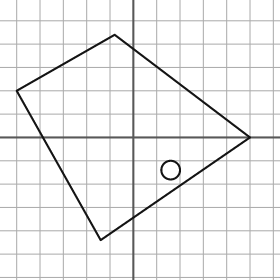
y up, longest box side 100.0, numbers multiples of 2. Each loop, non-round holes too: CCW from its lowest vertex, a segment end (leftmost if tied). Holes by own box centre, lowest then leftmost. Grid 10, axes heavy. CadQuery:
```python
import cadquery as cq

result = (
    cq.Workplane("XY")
    .moveTo(-14.0, -44.0)
    .lineTo(50.0, 0.0)
    .lineTo(-8.0, 44.0)
    .lineTo(-50.0, 20.0)
    .close()
    .moveTo(16.0, -14.0)
    .circle(4.0)
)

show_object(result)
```